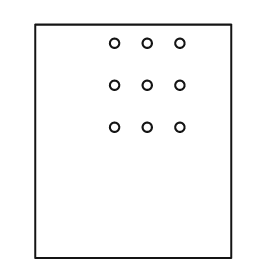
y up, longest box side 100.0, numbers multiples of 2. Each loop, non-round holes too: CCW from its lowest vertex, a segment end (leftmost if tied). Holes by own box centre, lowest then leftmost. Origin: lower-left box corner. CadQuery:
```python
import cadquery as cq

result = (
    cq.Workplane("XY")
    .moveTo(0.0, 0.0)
    .lineTo(84.0, 0.0)
    .lineTo(84.0, 100.0)
    .lineTo(0.0, 100.0)
    .close()
    .moveTo(34.0, 56.0)
    .circle(2.0)
    .moveTo(48.0, 56.0)
    .circle(2.0)
    .moveTo(62.0, 56.0)
    .circle(2.0)
    .moveTo(34.0, 74.0)
    .circle(2.0)
    .moveTo(48.0, 74.0)
    .circle(2.0)
    .moveTo(62.0, 74.0)
    .circle(2.0)
    .moveTo(34.0, 92.0)
    .circle(2.0)
    .moveTo(48.0, 92.0)
    .circle(2.0)
    .moveTo(62.0, 92.0)
    .circle(2.0)
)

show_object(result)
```